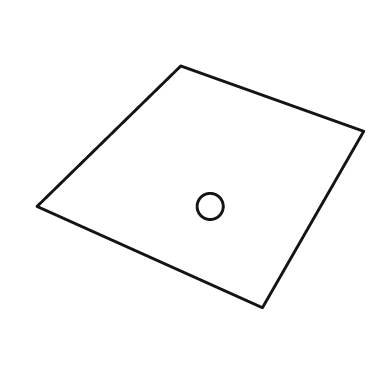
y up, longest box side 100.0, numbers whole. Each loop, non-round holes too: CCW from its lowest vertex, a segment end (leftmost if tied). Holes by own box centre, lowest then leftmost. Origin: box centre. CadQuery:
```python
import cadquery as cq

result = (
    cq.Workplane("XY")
    .moveTo(19.0, -37.0)
    .lineTo(50.0, 17.0)
    .lineTo(-6.0, 37.0)
    .lineTo(-50.0, -6.0)
    .close()
    .moveTo(3.0, -6.0)
    .circle(4.0)
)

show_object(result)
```